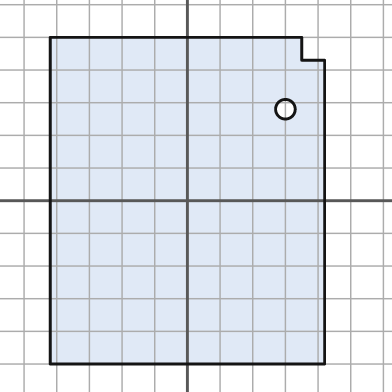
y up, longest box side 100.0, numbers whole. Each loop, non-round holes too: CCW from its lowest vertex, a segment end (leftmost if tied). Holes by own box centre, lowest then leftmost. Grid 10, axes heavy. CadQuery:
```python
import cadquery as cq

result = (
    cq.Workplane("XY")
    .moveTo(-42.0, -50.0)
    .lineTo(42.0, -50.0)
    .lineTo(42.0, 43.0)
    .lineTo(35.0, 43.0)
    .lineTo(35.0, 50.0)
    .lineTo(-42.0, 50.0)
    .close()
    .moveTo(30.0, 28.0)
    .circle(3.0)
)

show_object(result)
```